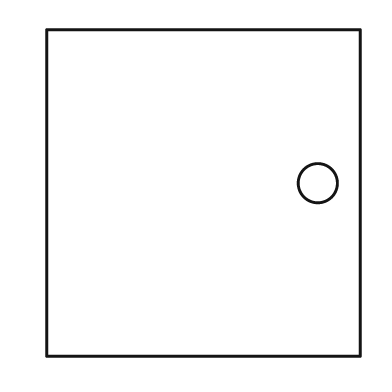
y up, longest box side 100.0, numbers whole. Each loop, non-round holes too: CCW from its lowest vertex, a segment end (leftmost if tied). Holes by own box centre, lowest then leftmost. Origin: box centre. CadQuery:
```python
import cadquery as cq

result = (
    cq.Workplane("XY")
    .moveTo(-48.0, -50.0)
    .lineTo(48.0, -50.0)
    .lineTo(48.0, 50.0)
    .lineTo(-48.0, 50.0)
    .close()
    .moveTo(35.0, 3.0)
    .circle(6.0)
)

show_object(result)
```